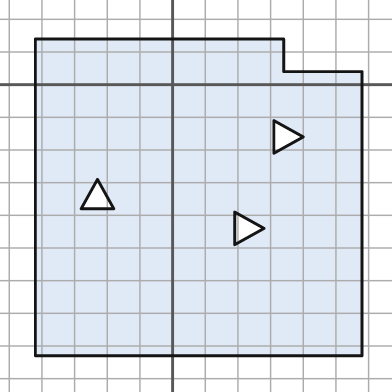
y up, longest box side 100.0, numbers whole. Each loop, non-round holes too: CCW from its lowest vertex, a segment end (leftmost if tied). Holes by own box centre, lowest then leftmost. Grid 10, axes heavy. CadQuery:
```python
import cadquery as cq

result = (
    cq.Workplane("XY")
    .moveTo(-42.0, -83.0)
    .lineTo(58.0, -83.0)
    .lineTo(58.0, 4.0)
    .lineTo(34.0, 4.0)
    .lineTo(34.0, 14.0)
    .lineTo(-42.0, 14.0)
    .close()
    .moveTo(19.0, -49.0)
    .lineTo(28.0, -44.0)
    .lineTo(19.0, -39.0)
    .close()
    .moveTo(-28.0, -38.0)
    .lineTo(-18.0, -38.0)
    .lineTo(-23.0, -29.0)
    .close()
    .moveTo(31.0, -21.0)
    .lineTo(40.0, -16.0)
    .lineTo(31.0, -11.0)
    .close()
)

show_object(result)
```